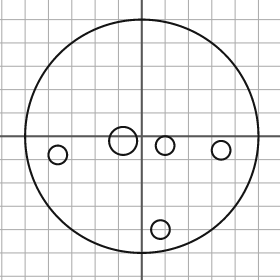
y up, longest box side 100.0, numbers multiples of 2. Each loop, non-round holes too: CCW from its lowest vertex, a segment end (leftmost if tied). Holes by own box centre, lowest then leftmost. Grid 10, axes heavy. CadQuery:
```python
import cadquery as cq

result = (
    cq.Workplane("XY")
    .moveTo(0.0, 0.0)
    .circle(50.0)
    .moveTo(8.0, -40.0)
    .circle(4.0)
    .moveTo(-36.0, -8.0)
    .circle(4.0)
    .moveTo(34.0, -6.0)
    .circle(4.0)
    .moveTo(10.0, -4.0)
    .circle(4.0)
    .moveTo(-8.0, -2.0)
    .circle(6.0)
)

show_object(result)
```